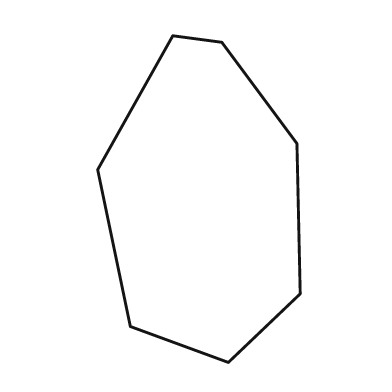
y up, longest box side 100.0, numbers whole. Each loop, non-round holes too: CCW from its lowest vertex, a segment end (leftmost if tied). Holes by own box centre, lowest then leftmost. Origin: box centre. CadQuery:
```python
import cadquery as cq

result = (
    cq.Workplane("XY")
    .moveTo(9.0, -50.0)
    .lineTo(31.0, -29.0)
    .lineTo(30.0, 17.0)
    .lineTo(7.0, 48.0)
    .lineTo(-8.0, 50.0)
    .lineTo(-31.0, 9.0)
    .lineTo(-21.0, -39.0)
    .close()
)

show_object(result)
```